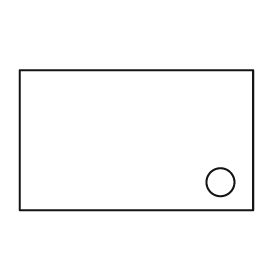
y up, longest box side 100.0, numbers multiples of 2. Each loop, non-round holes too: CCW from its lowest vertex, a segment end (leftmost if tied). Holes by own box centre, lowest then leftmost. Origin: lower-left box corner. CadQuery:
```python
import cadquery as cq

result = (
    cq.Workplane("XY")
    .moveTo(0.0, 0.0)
    .lineTo(100.0, 0.0)
    .lineTo(100.0, 60.0)
    .lineTo(0.0, 60.0)
    .close()
    .moveTo(86.0, 12.0)
    .circle(6.0)
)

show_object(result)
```